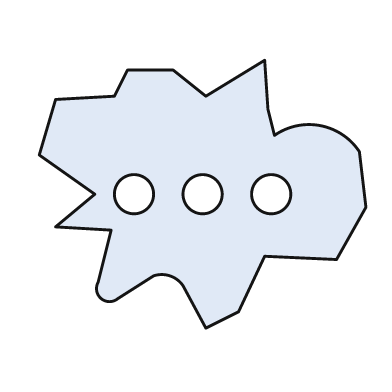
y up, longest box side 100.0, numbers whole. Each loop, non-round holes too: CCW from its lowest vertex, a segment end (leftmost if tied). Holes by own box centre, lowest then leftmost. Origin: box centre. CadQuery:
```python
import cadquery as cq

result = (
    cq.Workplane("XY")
    .moveTo(1.0, -41.0)
    .lineTo(11.0, -36.0)
    .lineTo(19.0, -19.0)
    .lineTo(41.0, -20.0)
    .lineTo(50.0, -4.0)
    .lineTo(48.0, 13.0)
    .threePointArc((36.0, 21.0), (22.0, 18.0))
    .lineTo(20.0, 26.0)
    .lineTo(19.0, 41.0)
    .lineTo(1.0, 30.0)
    .lineTo(-9.0, 38.0)
    .lineTo(-23.0, 38.0)
    .lineTo(-27.0, 30.0)
    .lineTo(-45.0, 29.0)
    .lineTo(-50.0, 12.0)
    .lineTo(-33.0, 0.0)
    .lineTo(-45.0, -10.0)
    .lineTo(-28.0, -11.0)
    .lineTo(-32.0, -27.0)
    .threePointArc((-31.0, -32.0), (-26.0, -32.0))
    .lineTo(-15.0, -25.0)
    .threePointArc((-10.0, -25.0), (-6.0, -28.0))
    .close()
    .moveTo(-21.0, 0.0)
    .circle(6.0)
    .moveTo(0.0, 0.0)
    .circle(6.0)
    .moveTo(21.0, 0.0)
    .circle(6.0)
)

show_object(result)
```